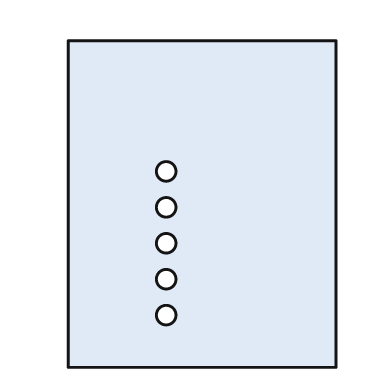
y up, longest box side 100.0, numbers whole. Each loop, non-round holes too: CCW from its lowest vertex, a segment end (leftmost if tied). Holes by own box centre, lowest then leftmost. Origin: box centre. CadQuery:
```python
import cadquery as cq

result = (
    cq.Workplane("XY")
    .moveTo(-41.0, -50.0)
    .lineTo(41.0, -50.0)
    .lineTo(41.0, 50.0)
    .lineTo(-41.0, 50.0)
    .close()
    .moveTo(-11.0, -34.0)
    .circle(3.0)
    .moveTo(-11.0, -23.0)
    .circle(3.0)
    .moveTo(-11.0, -12.0)
    .circle(3.0)
    .moveTo(-11.0, -1.0)
    .circle(3.0)
    .moveTo(-11.0, 10.0)
    .circle(3.0)
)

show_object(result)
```